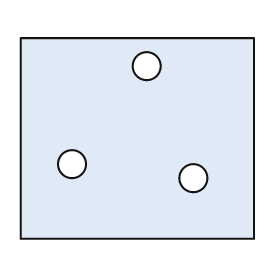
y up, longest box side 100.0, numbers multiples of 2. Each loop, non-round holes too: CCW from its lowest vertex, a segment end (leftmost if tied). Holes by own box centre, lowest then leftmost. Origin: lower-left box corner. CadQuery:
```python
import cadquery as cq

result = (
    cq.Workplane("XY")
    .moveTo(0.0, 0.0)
    .lineTo(100.0, 0.0)
    .lineTo(100.0, 86.0)
    .lineTo(0.0, 86.0)
    .close()
    .moveTo(74.0, 26.0)
    .circle(6.0)
    .moveTo(22.0, 32.0)
    .circle(6.0)
    .moveTo(54.0, 74.0)
    .circle(6.0)
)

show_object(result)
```